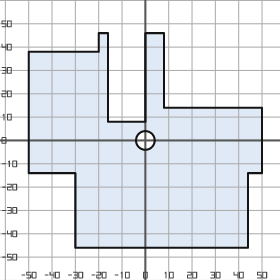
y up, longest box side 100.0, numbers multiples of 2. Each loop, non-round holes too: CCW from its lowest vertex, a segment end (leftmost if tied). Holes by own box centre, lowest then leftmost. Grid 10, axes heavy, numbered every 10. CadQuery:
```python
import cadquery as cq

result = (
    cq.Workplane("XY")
    .moveTo(-30.0, -46.0)
    .lineTo(44.0, -46.0)
    .lineTo(44.0, -14.0)
    .lineTo(50.0, -14.0)
    .lineTo(50.0, 14.0)
    .lineTo(8.0, 14.0)
    .lineTo(8.0, 46.0)
    .lineTo(0.0, 46.0)
    .lineTo(0.0, 8.0)
    .lineTo(-16.0, 8.0)
    .lineTo(-16.0, 46.0)
    .lineTo(-20.0, 46.0)
    .lineTo(-20.0, 38.0)
    .lineTo(-50.0, 38.0)
    .lineTo(-50.0, -14.0)
    .lineTo(-30.0, -14.0)
    .close()
    .moveTo(0.0, 0.0)
    .circle(4.0)
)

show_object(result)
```